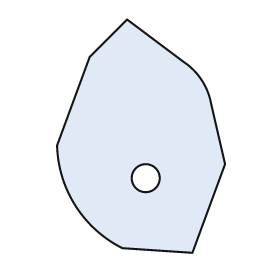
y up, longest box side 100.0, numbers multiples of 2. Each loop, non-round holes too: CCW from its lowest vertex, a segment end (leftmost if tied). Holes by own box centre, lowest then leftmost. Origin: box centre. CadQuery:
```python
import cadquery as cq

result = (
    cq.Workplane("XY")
    .moveTo(22.0, -50.0)
    .lineTo(36.0, -12.0)
    .lineTo(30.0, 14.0)
    .threePointArc((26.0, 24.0), (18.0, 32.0))
    .lineTo(-6.0, 50.0)
    .lineTo(-22.0, 34.0)
    .lineTo(-36.0, -4.0)
    .threePointArc((-28.0, -30.0), (-8.0, -48.0))
    .close()
    .moveTo(2.0, -18.0)
    .circle(6.0)
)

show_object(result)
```